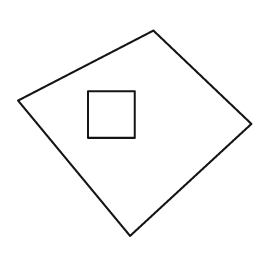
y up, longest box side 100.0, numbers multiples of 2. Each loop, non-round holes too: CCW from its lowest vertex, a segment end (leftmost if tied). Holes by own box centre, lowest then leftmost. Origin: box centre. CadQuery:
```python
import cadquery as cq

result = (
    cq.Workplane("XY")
    .moveTo(-2.0, -44.0)
    .lineTo(50.0, 4.0)
    .lineTo(8.0, 44.0)
    .lineTo(-50.0, 14.0)
    .close()
    .moveTo(-20.0, -2.0)
    .lineTo(0.0, -2.0)
    .lineTo(0.0, 18.0)
    .lineTo(-20.0, 18.0)
    .close()
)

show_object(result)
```